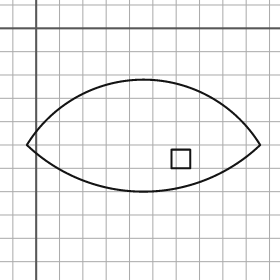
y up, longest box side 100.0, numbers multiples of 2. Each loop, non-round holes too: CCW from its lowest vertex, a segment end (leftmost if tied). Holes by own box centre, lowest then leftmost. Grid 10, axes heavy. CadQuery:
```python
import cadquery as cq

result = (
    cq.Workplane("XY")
    .moveTo(-4.0, -50.0)
    .threePointArc((46.0, -70.0), (96.0, -50.0))
    .threePointArc((46.0, -22.0), (-4.0, -50.0))
    .close()
    .moveTo(58.0, -60.0)
    .lineTo(66.0, -60.0)
    .lineTo(66.0, -52.0)
    .lineTo(58.0, -52.0)
    .close()
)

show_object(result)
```